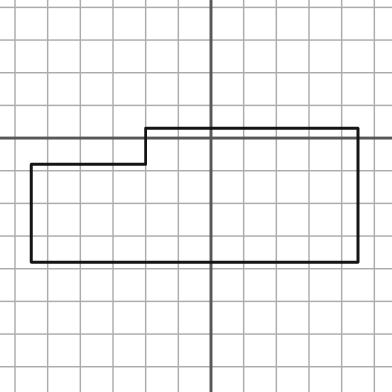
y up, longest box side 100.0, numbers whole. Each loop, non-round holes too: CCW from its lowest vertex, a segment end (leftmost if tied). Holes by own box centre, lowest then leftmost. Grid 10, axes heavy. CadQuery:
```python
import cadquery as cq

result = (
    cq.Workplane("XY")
    .moveTo(-55.0, -38.0)
    .lineTo(45.0, -38.0)
    .lineTo(45.0, 3.0)
    .lineTo(-20.0, 3.0)
    .lineTo(-20.0, -8.0)
    .lineTo(-55.0, -8.0)
    .close()
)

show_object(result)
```